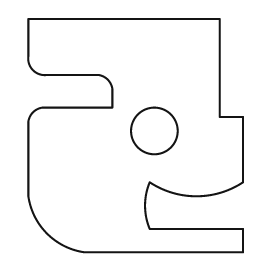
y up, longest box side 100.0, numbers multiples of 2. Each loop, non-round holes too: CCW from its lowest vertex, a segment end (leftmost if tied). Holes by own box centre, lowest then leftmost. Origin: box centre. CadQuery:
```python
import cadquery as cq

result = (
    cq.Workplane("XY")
    .moveTo(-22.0, -50.0)
    .lineTo(46.0, -50.0)
    .lineTo(46.0, -40.0)
    .lineTo(6.0, -40.0)
    .threePointArc((4.0, -30.0), (6.0, -20.0))
    .threePointArc((26.0, -26.0), (46.0, -20.0))
    .lineTo(46.0, 8.0)
    .lineTo(36.0, 8.0)
    .lineTo(36.0, 50.0)
    .lineTo(-46.0, 50.0)
    .lineTo(-46.0, 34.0)
    .threePointArc((-44.0, 28.0), (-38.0, 26.0))
    .lineTo(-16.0, 26.0)
    .threePointArc((-12.0, 24.0), (-10.0, 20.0))
    .lineTo(-10.0, 12.0)
    .lineTo(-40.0, 12.0)
    .threePointArc((-44.0, 10.0), (-46.0, 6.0))
    .lineTo(-46.0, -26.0)
    .threePointArc((-38.0, -42.0), (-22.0, -50.0))
    .close()
    .moveTo(8.0, 2.0)
    .circle(10.0)
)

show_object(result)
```